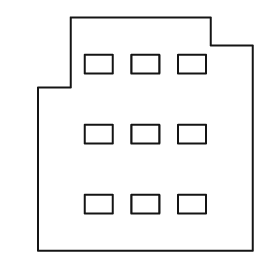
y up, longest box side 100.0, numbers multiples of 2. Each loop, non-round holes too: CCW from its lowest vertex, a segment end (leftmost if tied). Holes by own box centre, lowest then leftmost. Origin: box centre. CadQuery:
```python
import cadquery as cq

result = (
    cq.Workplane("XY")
    .moveTo(-46.0, -50.0)
    .lineTo(46.0, -50.0)
    .lineTo(46.0, 38.0)
    .lineTo(28.0, 38.0)
    .lineTo(28.0, 50.0)
    .lineTo(-32.0, 50.0)
    .lineTo(-32.0, 20.0)
    .lineTo(-46.0, 20.0)
    .close()
    .moveTo(-26.0, -34.0)
    .lineTo(-14.0, -34.0)
    .lineTo(-14.0, -26.0)
    .lineTo(-26.0, -26.0)
    .close()
    .moveTo(-6.0, -34.0)
    .lineTo(6.0, -34.0)
    .lineTo(6.0, -26.0)
    .lineTo(-6.0, -26.0)
    .close()
    .moveTo(14.0, -34.0)
    .lineTo(26.0, -34.0)
    .lineTo(26.0, -26.0)
    .lineTo(14.0, -26.0)
    .close()
    .moveTo(-26.0, -4.0)
    .lineTo(-14.0, -4.0)
    .lineTo(-14.0, 4.0)
    .lineTo(-26.0, 4.0)
    .close()
    .moveTo(-6.0, -4.0)
    .lineTo(6.0, -4.0)
    .lineTo(6.0, 4.0)
    .lineTo(-6.0, 4.0)
    .close()
    .moveTo(14.0, -4.0)
    .lineTo(26.0, -4.0)
    .lineTo(26.0, 4.0)
    .lineTo(14.0, 4.0)
    .close()
    .moveTo(-26.0, 26.0)
    .lineTo(-14.0, 26.0)
    .lineTo(-14.0, 34.0)
    .lineTo(-26.0, 34.0)
    .close()
    .moveTo(-6.0, 26.0)
    .lineTo(6.0, 26.0)
    .lineTo(6.0, 34.0)
    .lineTo(-6.0, 34.0)
    .close()
    .moveTo(14.0, 26.0)
    .lineTo(26.0, 26.0)
    .lineTo(26.0, 34.0)
    .lineTo(14.0, 34.0)
    .close()
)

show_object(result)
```